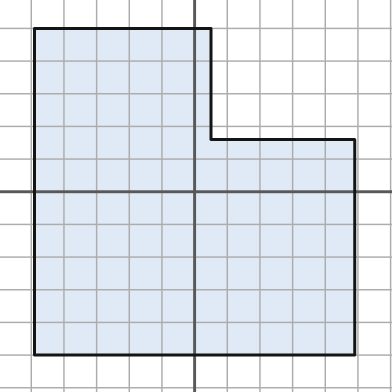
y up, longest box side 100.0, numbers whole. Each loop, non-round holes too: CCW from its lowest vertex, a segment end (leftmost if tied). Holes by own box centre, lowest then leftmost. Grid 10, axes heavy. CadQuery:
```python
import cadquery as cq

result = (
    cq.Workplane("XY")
    .moveTo(-49.0, -50.0)
    .lineTo(49.0, -50.0)
    .lineTo(49.0, 16.0)
    .lineTo(5.0, 16.0)
    .lineTo(5.0, 50.0)
    .lineTo(-49.0, 50.0)
    .close()
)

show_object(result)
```